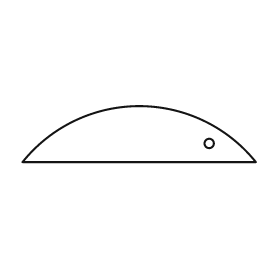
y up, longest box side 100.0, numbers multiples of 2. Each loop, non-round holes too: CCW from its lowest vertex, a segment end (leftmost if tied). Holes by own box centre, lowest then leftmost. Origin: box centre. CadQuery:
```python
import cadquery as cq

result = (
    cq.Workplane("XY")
    .moveTo(-50.0, -12.0)
    .lineTo(50.0, -12.0)
    .threePointArc((0.0, 12.0), (-50.0, -12.0))
    .close()
    .moveTo(30.0, -4.0)
    .circle(2.0)
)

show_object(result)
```